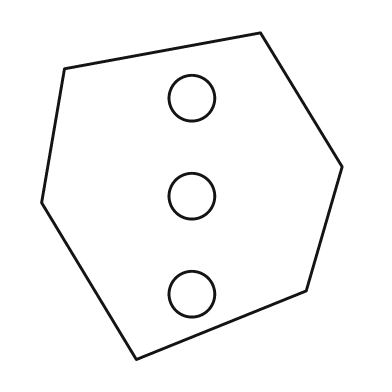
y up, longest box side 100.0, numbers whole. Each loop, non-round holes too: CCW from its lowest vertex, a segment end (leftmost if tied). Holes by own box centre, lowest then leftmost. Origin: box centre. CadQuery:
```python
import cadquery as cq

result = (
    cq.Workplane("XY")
    .moveTo(-17.0, -50.0)
    .lineTo(35.0, -29.0)
    .lineTo(46.0, 9.0)
    .lineTo(21.0, 50.0)
    .lineTo(-39.0, 39.0)
    .lineTo(-46.0, -2.0)
    .close()
    .moveTo(0.0, -30.0)
    .circle(7.0)
    .moveTo(0.0, 0.0)
    .circle(7.0)
    .moveTo(0.0, 30.0)
    .circle(7.0)
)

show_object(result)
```